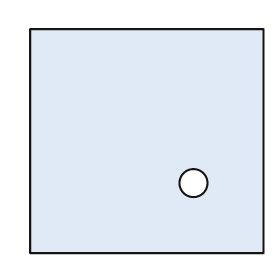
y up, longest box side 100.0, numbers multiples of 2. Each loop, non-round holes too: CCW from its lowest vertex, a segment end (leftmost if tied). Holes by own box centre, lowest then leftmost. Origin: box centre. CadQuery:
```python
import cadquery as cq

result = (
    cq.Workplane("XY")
    .moveTo(-50.0, -48.0)
    .lineTo(50.0, -48.0)
    .lineTo(50.0, 48.0)
    .lineTo(-50.0, 48.0)
    .close()
    .moveTo(20.0, -18.0)
    .circle(6.0)
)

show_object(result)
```